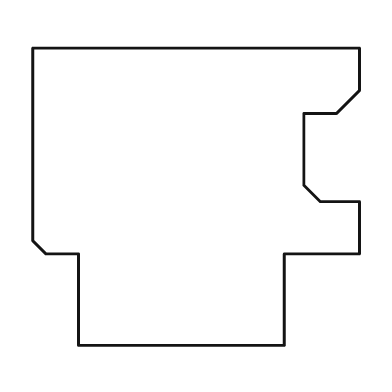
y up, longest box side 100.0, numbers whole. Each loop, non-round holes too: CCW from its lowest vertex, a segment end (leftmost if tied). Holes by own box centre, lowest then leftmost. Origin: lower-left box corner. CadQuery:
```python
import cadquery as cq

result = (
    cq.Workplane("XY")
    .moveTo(14.0, 0.0)
    .lineTo(77.0, 0.0)
    .lineTo(77.0, 28.0)
    .lineTo(100.0, 28.0)
    .lineTo(100.0, 44.0)
    .lineTo(88.0, 44.0)
    .lineTo(83.0, 49.0)
    .lineTo(83.0, 71.0)
    .lineTo(93.0, 71.0)
    .lineTo(100.0, 78.0)
    .lineTo(100.0, 91.0)
    .lineTo(0.0, 91.0)
    .lineTo(0.0, 32.0)
    .lineTo(4.0, 28.0)
    .lineTo(14.0, 28.0)
    .close()
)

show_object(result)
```